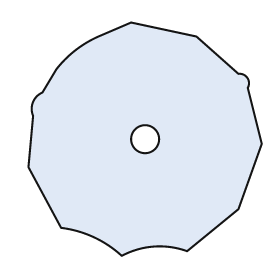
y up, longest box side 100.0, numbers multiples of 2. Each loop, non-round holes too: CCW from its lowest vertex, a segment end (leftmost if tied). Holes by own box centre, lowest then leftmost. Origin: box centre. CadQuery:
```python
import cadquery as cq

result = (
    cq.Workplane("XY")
    .moveTo(-10.0, -50.0)
    .threePointArc((4.0, -46.0), (18.0, -48.0))
    .lineTo(40.0, -30.0)
    .lineTo(50.0, -2.0)
    .lineTo(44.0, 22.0)
    .threePointArc((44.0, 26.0), (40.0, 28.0))
    .lineTo(22.0, 44.0)
    .lineTo(-6.0, 50.0)
    .lineTo(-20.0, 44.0)
    .threePointArc((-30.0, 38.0), (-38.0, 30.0))
    .lineTo(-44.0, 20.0)
    .threePointArc((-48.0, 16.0), (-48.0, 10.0))
    .lineTo(-50.0, -12.0)
    .lineTo(-36.0, -38.0)
    .threePointArc((-22.0, -42.0), (-10.0, -50.0))
    .close()
    .moveTo(0.0, 0.0)
    .circle(6.0)
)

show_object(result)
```